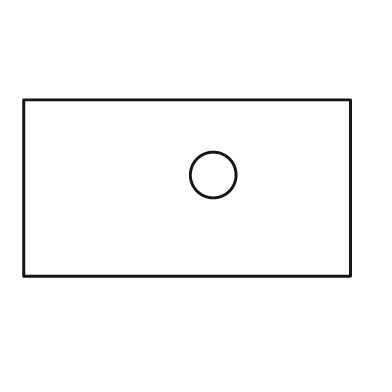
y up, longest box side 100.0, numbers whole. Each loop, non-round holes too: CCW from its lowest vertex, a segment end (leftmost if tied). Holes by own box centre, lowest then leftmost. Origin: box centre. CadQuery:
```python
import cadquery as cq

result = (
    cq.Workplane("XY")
    .moveTo(-50.0, -27.0)
    .lineTo(50.0, -27.0)
    .lineTo(50.0, 27.0)
    .lineTo(-50.0, 27.0)
    .close()
    .moveTo(8.0, 4.0)
    .circle(7.0)
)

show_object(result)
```